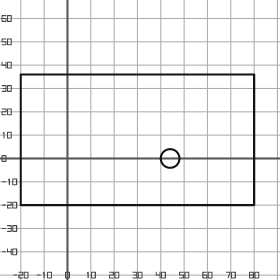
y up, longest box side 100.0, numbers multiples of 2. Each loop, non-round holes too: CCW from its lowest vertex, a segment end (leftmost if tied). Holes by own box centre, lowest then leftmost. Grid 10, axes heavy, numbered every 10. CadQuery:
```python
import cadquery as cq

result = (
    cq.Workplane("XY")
    .moveTo(-20.0, -20.0)
    .lineTo(80.0, -20.0)
    .lineTo(80.0, 36.0)
    .lineTo(-20.0, 36.0)
    .close()
    .moveTo(44.0, 0.0)
    .circle(4.0)
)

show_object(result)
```